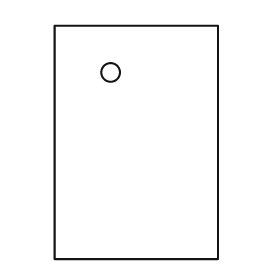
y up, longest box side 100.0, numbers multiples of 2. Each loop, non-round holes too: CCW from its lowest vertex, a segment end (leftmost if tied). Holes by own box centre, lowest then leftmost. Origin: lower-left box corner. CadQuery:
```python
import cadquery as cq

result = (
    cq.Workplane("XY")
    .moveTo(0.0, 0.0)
    .lineTo(70.0, 0.0)
    .lineTo(70.0, 100.0)
    .lineTo(0.0, 100.0)
    .close()
    .moveTo(24.0, 80.0)
    .circle(4.0)
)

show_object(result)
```